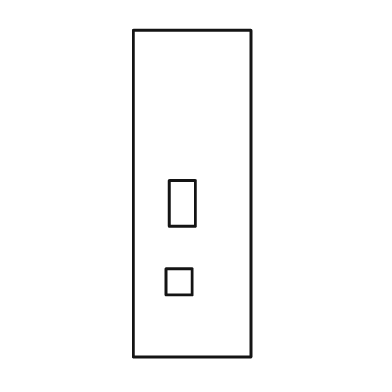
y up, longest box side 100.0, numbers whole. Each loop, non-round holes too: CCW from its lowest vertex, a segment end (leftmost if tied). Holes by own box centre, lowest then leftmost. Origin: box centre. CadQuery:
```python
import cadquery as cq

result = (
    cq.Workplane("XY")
    .moveTo(-18.0, -50.0)
    .lineTo(18.0, -50.0)
    .lineTo(18.0, 50.0)
    .lineTo(-18.0, 50.0)
    .close()
    .moveTo(-8.0, -31.0)
    .lineTo(0.0, -31.0)
    .lineTo(0.0, -23.0)
    .lineTo(-8.0, -23.0)
    .close()
    .moveTo(-7.0, -10.0)
    .lineTo(1.0, -10.0)
    .lineTo(1.0, 4.0)
    .lineTo(-7.0, 4.0)
    .close()
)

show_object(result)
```